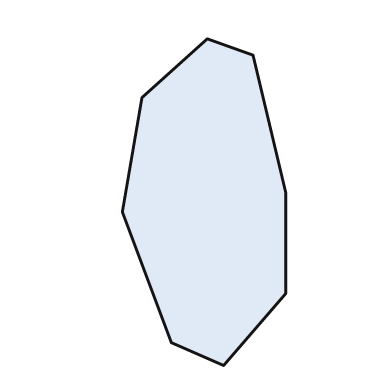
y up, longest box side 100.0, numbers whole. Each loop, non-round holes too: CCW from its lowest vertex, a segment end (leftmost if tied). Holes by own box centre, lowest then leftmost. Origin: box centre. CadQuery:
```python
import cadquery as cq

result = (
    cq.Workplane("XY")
    .moveTo(6.0, -50.0)
    .lineTo(25.0, -28.0)
    .lineTo(25.0, 3.0)
    .lineTo(15.0, 45.0)
    .lineTo(1.0, 50.0)
    .lineTo(-19.0, 32.0)
    .lineTo(-25.0, -3.0)
    .lineTo(-10.0, -43.0)
    .close()
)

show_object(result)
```